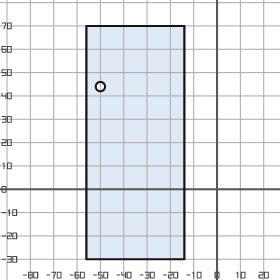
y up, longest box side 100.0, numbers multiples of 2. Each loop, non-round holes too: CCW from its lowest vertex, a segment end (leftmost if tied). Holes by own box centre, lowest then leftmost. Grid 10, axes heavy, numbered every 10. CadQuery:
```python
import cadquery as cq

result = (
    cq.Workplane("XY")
    .moveTo(-56.0, -30.0)
    .lineTo(-14.0, -30.0)
    .lineTo(-14.0, 70.0)
    .lineTo(-56.0, 70.0)
    .close()
    .moveTo(-50.0, 44.0)
    .circle(2.0)
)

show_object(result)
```